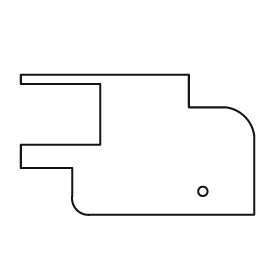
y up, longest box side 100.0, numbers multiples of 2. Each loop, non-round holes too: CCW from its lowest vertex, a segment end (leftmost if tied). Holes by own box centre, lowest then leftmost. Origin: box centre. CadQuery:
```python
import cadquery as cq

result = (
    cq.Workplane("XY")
    .moveTo(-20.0, -30.0)
    .lineTo(50.0, -30.0)
    .lineTo(50.0, 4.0)
    .threePointArc((46.0, 12.0), (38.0, 16.0))
    .lineTo(22.0, 16.0)
    .lineTo(22.0, 30.0)
    .lineTo(-50.0, 30.0)
    .lineTo(-50.0, 26.0)
    .lineTo(-16.0, 26.0)
    .lineTo(-16.0, 0.0)
    .lineTo(-50.0, 0.0)
    .lineTo(-50.0, -10.0)
    .lineTo(-28.0, -10.0)
    .lineTo(-28.0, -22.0)
    .threePointArc((-26.0, -28.0), (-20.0, -30.0))
    .close()
    .moveTo(28.0, -20.0)
    .circle(2.0)
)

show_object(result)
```